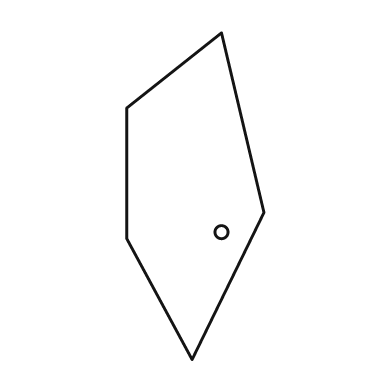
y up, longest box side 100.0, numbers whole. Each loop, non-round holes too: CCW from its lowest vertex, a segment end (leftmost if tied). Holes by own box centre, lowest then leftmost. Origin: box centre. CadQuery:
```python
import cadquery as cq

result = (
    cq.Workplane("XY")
    .moveTo(-1.0, -50.0)
    .lineTo(21.0, -5.0)
    .lineTo(8.0, 50.0)
    .lineTo(-21.0, 27.0)
    .lineTo(-21.0, -13.0)
    .close()
    .moveTo(8.0, -11.0)
    .circle(2.0)
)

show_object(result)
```